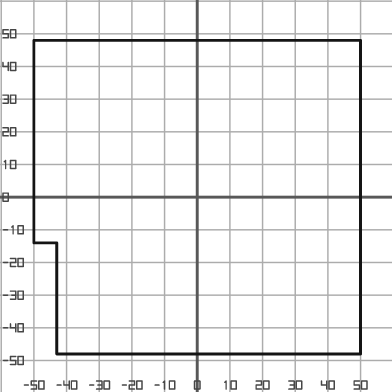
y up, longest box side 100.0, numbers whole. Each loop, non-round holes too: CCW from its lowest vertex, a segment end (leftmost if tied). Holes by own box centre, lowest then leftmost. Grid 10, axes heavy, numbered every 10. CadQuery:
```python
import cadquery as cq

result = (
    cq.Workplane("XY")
    .moveTo(-43.0, -48.0)
    .lineTo(50.0, -48.0)
    .lineTo(50.0, 48.0)
    .lineTo(-50.0, 48.0)
    .lineTo(-50.0, -14.0)
    .lineTo(-43.0, -14.0)
    .close()
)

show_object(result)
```